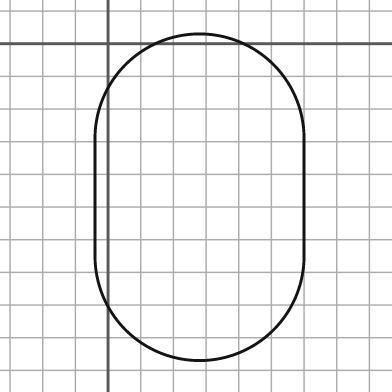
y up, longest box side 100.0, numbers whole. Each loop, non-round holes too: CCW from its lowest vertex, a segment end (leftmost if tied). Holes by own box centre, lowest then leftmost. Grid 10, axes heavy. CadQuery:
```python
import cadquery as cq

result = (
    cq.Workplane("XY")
    .moveTo(-4.0, -65.0)
    .threePointArc((28.0, -97.0), (60.0, -65.0))
    .lineTo(60.0, -29.0)
    .threePointArc((28.0, 3.0), (-4.0, -29.0))
    .close()
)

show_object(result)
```